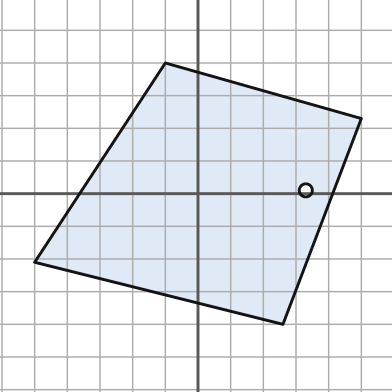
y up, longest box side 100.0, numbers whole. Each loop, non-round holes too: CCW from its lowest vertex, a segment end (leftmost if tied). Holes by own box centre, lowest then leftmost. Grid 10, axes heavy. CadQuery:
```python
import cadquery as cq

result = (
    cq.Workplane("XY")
    .moveTo(26.0, -40.0)
    .lineTo(50.0, 23.0)
    .lineTo(-10.0, 40.0)
    .lineTo(-50.0, -21.0)
    .close()
    .moveTo(33.0, 1.0)
    .circle(2.0)
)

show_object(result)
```